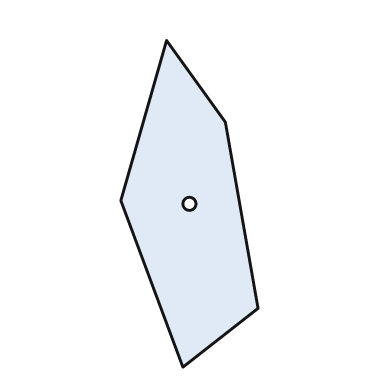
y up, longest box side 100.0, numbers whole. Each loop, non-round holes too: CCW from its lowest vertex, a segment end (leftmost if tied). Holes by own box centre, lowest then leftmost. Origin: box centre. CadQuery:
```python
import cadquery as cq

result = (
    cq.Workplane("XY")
    .moveTo(-2.0, -50.0)
    .lineTo(21.0, -32.0)
    .lineTo(11.0, 25.0)
    .lineTo(-7.0, 50.0)
    .lineTo(-21.0, 1.0)
    .close()
    .moveTo(0.0, 0.0)
    .circle(2.0)
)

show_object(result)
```